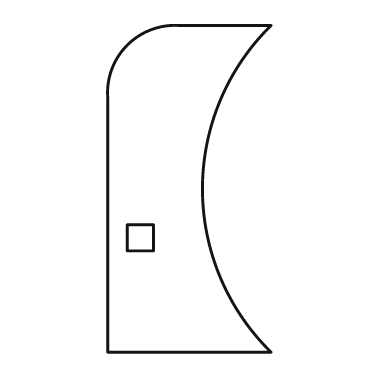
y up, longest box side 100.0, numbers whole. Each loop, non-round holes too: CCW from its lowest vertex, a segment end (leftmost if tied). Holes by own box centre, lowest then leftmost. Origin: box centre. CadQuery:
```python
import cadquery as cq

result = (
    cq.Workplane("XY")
    .moveTo(-25.0, -50.0)
    .lineTo(25.0, -50.0)
    .threePointArc((4.0, 0.0), (25.0, 50.0))
    .lineTo(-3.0, 50.0)
    .threePointArc((-19.0, 44.0), (-25.0, 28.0))
    .close()
    .moveTo(-19.0, -19.0)
    .lineTo(-11.0, -19.0)
    .lineTo(-11.0, -11.0)
    .lineTo(-19.0, -11.0)
    .close()
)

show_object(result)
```